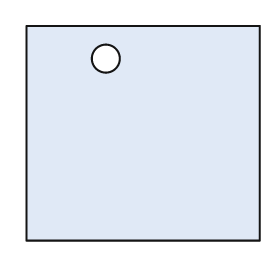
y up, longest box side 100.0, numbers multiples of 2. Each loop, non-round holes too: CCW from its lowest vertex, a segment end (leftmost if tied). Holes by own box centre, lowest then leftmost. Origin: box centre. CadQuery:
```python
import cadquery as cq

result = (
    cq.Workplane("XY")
    .moveTo(-50.0, -46.0)
    .lineTo(50.0, -46.0)
    .lineTo(50.0, 46.0)
    .lineTo(-50.0, 46.0)
    .close()
    .moveTo(-16.0, 32.0)
    .circle(6.0)
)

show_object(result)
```